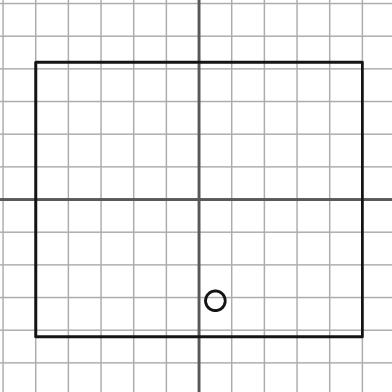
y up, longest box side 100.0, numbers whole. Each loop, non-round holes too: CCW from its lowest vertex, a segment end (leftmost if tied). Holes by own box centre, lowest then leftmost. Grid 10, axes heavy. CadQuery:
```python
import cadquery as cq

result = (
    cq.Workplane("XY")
    .moveTo(-50.0, -42.0)
    .lineTo(50.0, -42.0)
    .lineTo(50.0, 42.0)
    .lineTo(-50.0, 42.0)
    .close()
    .moveTo(5.0, -31.0)
    .circle(3.0)
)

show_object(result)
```